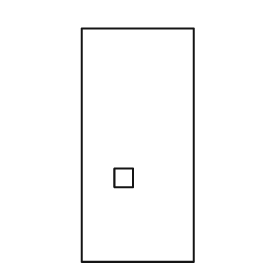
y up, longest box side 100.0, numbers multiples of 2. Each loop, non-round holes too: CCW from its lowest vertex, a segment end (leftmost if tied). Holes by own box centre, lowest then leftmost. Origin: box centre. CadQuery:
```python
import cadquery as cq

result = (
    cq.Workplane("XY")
    .moveTo(-24.0, -50.0)
    .lineTo(24.0, -50.0)
    .lineTo(24.0, 50.0)
    .lineTo(-24.0, 50.0)
    .close()
    .moveTo(-10.0, -18.0)
    .lineTo(-2.0, -18.0)
    .lineTo(-2.0, -10.0)
    .lineTo(-10.0, -10.0)
    .close()
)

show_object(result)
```